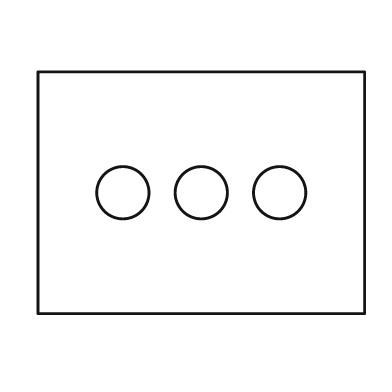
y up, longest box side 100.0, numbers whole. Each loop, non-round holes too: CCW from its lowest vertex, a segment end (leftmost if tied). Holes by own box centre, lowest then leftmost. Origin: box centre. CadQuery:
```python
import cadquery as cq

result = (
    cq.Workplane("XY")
    .moveTo(-50.0, -37.0)
    .lineTo(50.0, -37.0)
    .lineTo(50.0, 37.0)
    .lineTo(-50.0, 37.0)
    .close()
    .moveTo(-24.0, 0.0)
    .circle(8.0)
    .moveTo(0.0, 0.0)
    .circle(8.0)
    .moveTo(24.0, 0.0)
    .circle(8.0)
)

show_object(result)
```